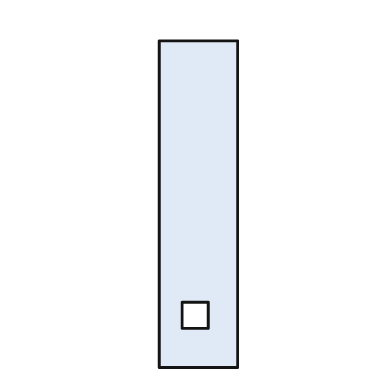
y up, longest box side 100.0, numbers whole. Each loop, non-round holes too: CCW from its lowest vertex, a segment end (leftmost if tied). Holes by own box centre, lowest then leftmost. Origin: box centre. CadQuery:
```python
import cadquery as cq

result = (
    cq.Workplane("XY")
    .moveTo(-12.0, -50.0)
    .lineTo(12.0, -50.0)
    .lineTo(12.0, 50.0)
    .lineTo(-12.0, 50.0)
    .close()
    .moveTo(-5.0, -38.0)
    .lineTo(3.0, -38.0)
    .lineTo(3.0, -30.0)
    .lineTo(-5.0, -30.0)
    .close()
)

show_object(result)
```